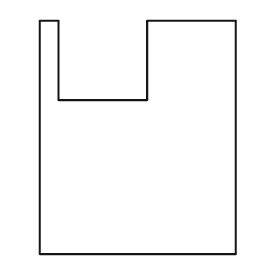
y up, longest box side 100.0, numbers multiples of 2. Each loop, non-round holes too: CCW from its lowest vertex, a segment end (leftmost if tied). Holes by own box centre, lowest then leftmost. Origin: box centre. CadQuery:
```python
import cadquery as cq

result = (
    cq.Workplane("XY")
    .moveTo(-42.0, -50.0)
    .lineTo(42.0, -50.0)
    .lineTo(42.0, 50.0)
    .lineTo(4.0, 50.0)
    .lineTo(4.0, 16.0)
    .lineTo(-34.0, 16.0)
    .lineTo(-34.0, 50.0)
    .lineTo(-42.0, 50.0)
    .close()
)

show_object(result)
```